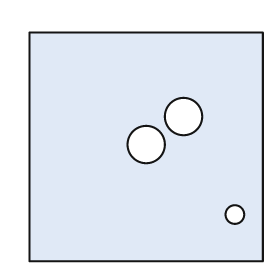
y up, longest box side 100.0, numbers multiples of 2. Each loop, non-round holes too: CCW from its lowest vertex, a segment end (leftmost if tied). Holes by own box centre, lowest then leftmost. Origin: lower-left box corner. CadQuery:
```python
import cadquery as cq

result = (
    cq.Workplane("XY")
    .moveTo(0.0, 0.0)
    .lineTo(100.0, 0.0)
    .lineTo(100.0, 98.0)
    .lineTo(0.0, 98.0)
    .close()
    .moveTo(88.0, 20.0)
    .circle(4.0)
    .moveTo(50.0, 50.0)
    .circle(8.0)
    .moveTo(66.0, 62.0)
    .circle(8.0)
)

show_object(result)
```